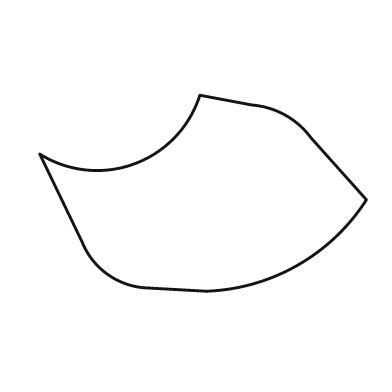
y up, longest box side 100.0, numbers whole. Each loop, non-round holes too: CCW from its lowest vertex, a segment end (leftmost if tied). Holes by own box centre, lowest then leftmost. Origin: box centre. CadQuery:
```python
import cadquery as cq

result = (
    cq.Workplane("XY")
    .moveTo(1.0, -30.0)
    .threePointArc((29.0, -22.0), (50.0, -2.0))
    .lineTo(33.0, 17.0)
    .threePointArc((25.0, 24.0), (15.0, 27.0))
    .lineTo(-1.0, 30.0)
    .threePointArc((-21.0, 9.0), (-50.0, 12.0))
    .lineTo(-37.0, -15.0)
    .threePointArc((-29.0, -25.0), (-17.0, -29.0))
    .close()
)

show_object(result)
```